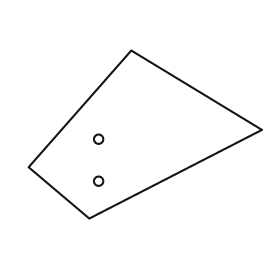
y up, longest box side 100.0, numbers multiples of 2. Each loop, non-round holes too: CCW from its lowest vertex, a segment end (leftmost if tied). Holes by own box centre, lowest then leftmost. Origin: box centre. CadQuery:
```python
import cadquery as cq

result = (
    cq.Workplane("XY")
    .moveTo(-24.0, -36.0)
    .lineTo(50.0, 2.0)
    .lineTo(-6.0, 36.0)
    .lineTo(-50.0, -14.0)
    .close()
    .moveTo(-20.0, -20.0)
    .circle(2.0)
    .moveTo(-20.0, -2.0)
    .circle(2.0)
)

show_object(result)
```